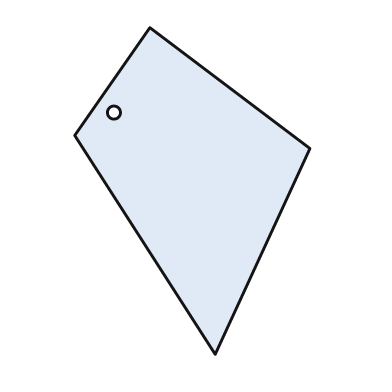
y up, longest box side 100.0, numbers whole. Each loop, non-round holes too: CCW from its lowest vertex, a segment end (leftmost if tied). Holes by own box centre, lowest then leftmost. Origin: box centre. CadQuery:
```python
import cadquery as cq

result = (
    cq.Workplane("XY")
    .moveTo(7.0, -50.0)
    .lineTo(36.0, 13.0)
    .lineTo(-13.0, 50.0)
    .lineTo(-36.0, 17.0)
    .close()
    .moveTo(-24.0, 24.0)
    .circle(2.0)
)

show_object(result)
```